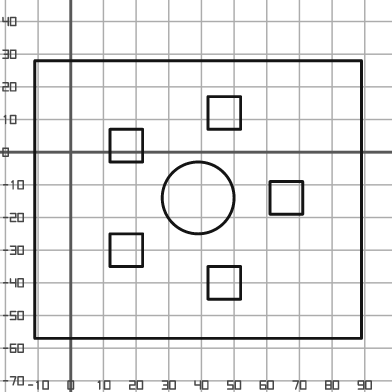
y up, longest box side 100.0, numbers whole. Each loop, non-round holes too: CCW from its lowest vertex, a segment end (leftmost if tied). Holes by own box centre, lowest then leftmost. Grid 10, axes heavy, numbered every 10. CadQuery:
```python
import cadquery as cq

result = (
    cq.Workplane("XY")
    .moveTo(-11.0, -57.0)
    .lineTo(89.0, -57.0)
    .lineTo(89.0, 28.0)
    .lineTo(-11.0, 28.0)
    .close()
    .moveTo(42.0, -45.0)
    .lineTo(52.0, -45.0)
    .lineTo(52.0, -35.0)
    .lineTo(42.0, -35.0)
    .close()
    .moveTo(12.0, -35.0)
    .lineTo(22.0, -35.0)
    .lineTo(22.0, -25.0)
    .lineTo(12.0, -25.0)
    .close()
    .moveTo(39.0, -14.0)
    .circle(11.0)
    .moveTo(61.0, -19.0)
    .lineTo(71.0, -19.0)
    .lineTo(71.0, -9.0)
    .lineTo(61.0, -9.0)
    .close()
    .moveTo(12.0, -3.0)
    .lineTo(22.0, -3.0)
    .lineTo(22.0, 7.0)
    .lineTo(12.0, 7.0)
    .close()
    .moveTo(42.0, 7.0)
    .lineTo(52.0, 7.0)
    .lineTo(52.0, 17.0)
    .lineTo(42.0, 17.0)
    .close()
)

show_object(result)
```